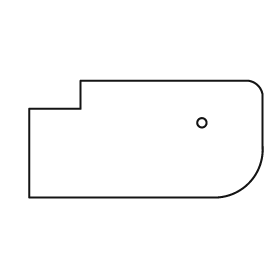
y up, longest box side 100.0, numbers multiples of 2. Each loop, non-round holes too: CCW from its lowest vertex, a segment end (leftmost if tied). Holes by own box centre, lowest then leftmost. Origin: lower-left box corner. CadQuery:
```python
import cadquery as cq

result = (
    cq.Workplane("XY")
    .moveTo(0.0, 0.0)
    .lineTo(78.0, 0.0)
    .threePointArc((94.0, 6.0), (100.0, 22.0))
    .lineTo(100.0, 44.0)
    .threePointArc((98.0, 48.0), (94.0, 50.0))
    .lineTo(22.0, 50.0)
    .lineTo(22.0, 38.0)
    .lineTo(0.0, 38.0)
    .close()
    .moveTo(74.0, 32.0)
    .circle(2.0)
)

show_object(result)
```